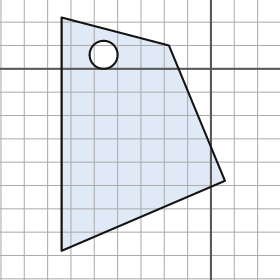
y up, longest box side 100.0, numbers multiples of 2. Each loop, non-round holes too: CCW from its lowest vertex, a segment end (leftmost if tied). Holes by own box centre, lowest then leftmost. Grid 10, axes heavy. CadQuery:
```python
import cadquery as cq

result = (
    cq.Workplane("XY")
    .moveTo(-64.0, -78.0)
    .lineTo(6.0, -48.0)
    .lineTo(-18.0, 10.0)
    .lineTo(-64.0, 22.0)
    .close()
    .moveTo(-46.0, 6.0)
    .circle(6.0)
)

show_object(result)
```